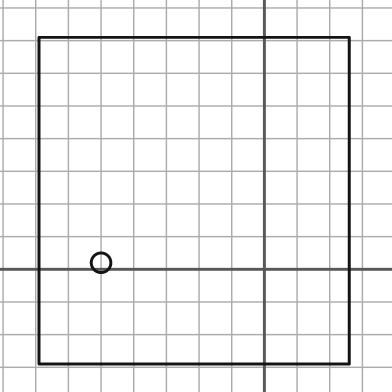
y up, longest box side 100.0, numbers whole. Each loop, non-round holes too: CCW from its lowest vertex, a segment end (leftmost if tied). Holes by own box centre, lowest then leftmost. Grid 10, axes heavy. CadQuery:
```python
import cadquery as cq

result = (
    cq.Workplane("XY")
    .moveTo(-69.0, -29.0)
    .lineTo(26.0, -29.0)
    .lineTo(26.0, 71.0)
    .lineTo(-69.0, 71.0)
    .close()
    .moveTo(-50.0, 2.0)
    .circle(3.0)
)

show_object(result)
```